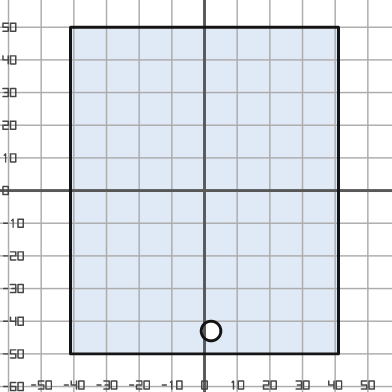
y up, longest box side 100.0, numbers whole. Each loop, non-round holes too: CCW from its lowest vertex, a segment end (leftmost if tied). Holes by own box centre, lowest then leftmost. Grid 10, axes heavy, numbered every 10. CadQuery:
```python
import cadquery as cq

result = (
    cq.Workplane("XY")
    .moveTo(-41.0, -50.0)
    .lineTo(41.0, -50.0)
    .lineTo(41.0, 50.0)
    .lineTo(-41.0, 50.0)
    .close()
    .moveTo(2.0, -43.0)
    .circle(3.0)
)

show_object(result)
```